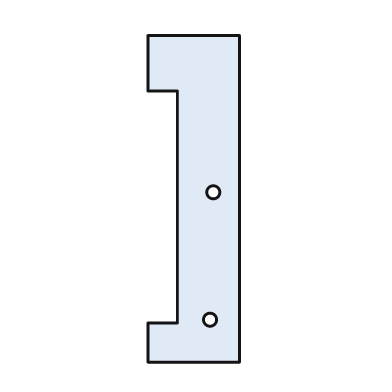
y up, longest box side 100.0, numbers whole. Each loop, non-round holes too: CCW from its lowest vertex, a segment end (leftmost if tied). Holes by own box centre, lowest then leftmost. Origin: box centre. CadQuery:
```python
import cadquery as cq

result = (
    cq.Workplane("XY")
    .moveTo(-14.0, -50.0)
    .lineTo(14.0, -50.0)
    .lineTo(14.0, 50.0)
    .lineTo(-14.0, 50.0)
    .lineTo(-14.0, 33.0)
    .lineTo(-5.0, 33.0)
    .lineTo(-5.0, -38.0)
    .lineTo(-14.0, -38.0)
    .close()
    .moveTo(5.0, -37.0)
    .circle(2.0)
    .moveTo(6.0, 2.0)
    .circle(2.0)
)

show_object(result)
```